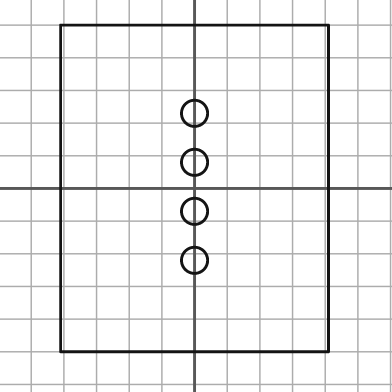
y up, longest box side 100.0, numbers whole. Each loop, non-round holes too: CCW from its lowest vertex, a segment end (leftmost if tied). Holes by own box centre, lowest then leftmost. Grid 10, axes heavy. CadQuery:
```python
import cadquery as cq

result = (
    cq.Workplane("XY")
    .moveTo(-41.0, -50.0)
    .lineTo(41.0, -50.0)
    .lineTo(41.0, 50.0)
    .lineTo(-41.0, 50.0)
    .close()
    .moveTo(0.0, -22.0)
    .circle(4.0)
    .moveTo(0.0, -7.0)
    .circle(4.0)
    .moveTo(0.0, 8.0)
    .circle(4.0)
    .moveTo(0.0, 23.0)
    .circle(4.0)
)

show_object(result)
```